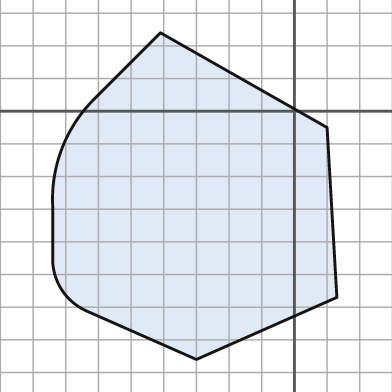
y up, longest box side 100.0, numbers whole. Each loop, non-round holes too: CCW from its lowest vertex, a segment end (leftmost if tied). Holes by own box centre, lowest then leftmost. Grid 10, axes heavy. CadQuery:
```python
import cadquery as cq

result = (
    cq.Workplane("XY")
    .moveTo(-30.0, -76.0)
    .lineTo(13.0, -57.0)
    .lineTo(10.0, -5.0)
    .lineTo(-41.0, 24.0)
    .lineTo(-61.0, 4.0)
    .threePointArc((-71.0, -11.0), (-74.0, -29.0))
    .lineTo(-74.0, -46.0)
    .threePointArc((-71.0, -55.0), (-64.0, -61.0))
    .close()
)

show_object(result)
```